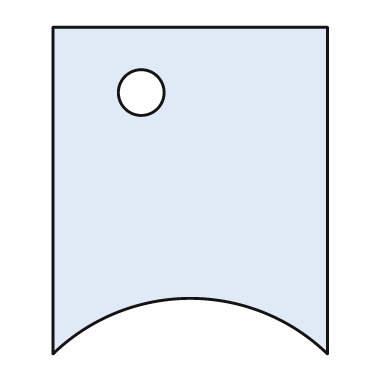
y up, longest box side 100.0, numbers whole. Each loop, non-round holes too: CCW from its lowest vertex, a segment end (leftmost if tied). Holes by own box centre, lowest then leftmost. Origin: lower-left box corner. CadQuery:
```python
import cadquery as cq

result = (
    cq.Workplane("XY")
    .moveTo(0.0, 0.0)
    .threePointArc((42.0, 17.0), (84.0, 0.0))
    .lineTo(84.0, 100.0)
    .lineTo(0.0, 100.0)
    .close()
    .moveTo(27.0, 80.0)
    .circle(7.0)
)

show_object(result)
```